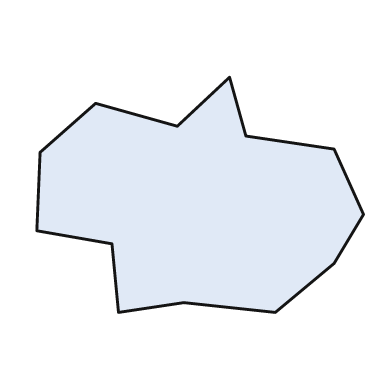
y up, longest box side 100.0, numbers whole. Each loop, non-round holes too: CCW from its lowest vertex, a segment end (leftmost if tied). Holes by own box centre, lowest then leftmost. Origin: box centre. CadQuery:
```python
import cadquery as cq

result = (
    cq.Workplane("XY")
    .moveTo(-25.0, -36.0)
    .lineTo(-5.0, -33.0)
    .lineTo(23.0, -36.0)
    .lineTo(41.0, -21.0)
    .lineTo(50.0, -6.0)
    .lineTo(41.0, 14.0)
    .lineTo(14.0, 18.0)
    .lineTo(9.0, 36.0)
    .lineTo(-7.0, 21.0)
    .lineTo(-32.0, 28.0)
    .lineTo(-49.0, 13.0)
    .lineTo(-50.0, -11.0)
    .lineTo(-27.0, -15.0)
    .close()
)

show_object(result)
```